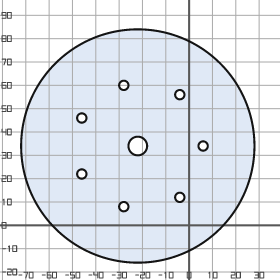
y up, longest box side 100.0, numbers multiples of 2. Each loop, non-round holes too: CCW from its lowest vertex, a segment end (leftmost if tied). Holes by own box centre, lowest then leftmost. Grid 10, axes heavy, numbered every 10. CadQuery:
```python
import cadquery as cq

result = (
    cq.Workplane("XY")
    .moveTo(-22.0, 34.0)
    .circle(50.0)
    .moveTo(-28.0, 8.0)
    .circle(2.0)
    .moveTo(-4.0, 12.0)
    .circle(2.0)
    .moveTo(-46.0, 22.0)
    .circle(2.0)
    .moveTo(-22.0, 34.0)
    .circle(4.0)
    .moveTo(6.0, 34.0)
    .circle(2.0)
    .moveTo(-46.0, 46.0)
    .circle(2.0)
    .moveTo(-4.0, 56.0)
    .circle(2.0)
    .moveTo(-28.0, 60.0)
    .circle(2.0)
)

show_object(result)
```